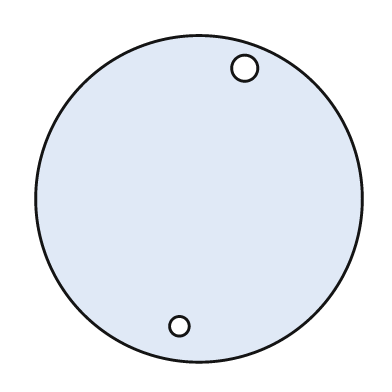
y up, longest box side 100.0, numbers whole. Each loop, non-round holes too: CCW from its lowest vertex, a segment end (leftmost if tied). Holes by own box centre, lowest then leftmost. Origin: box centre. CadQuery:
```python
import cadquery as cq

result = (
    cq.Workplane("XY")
    .moveTo(0.0, 0.0)
    .circle(50.0)
    .moveTo(-6.0, -39.0)
    .circle(3.0)
    .moveTo(14.0, 40.0)
    .circle(4.0)
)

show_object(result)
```